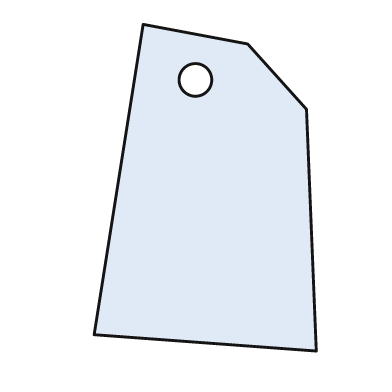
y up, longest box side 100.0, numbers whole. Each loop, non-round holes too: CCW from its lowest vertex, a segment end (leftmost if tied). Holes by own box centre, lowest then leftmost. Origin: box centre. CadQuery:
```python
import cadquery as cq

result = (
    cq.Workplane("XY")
    .moveTo(34.0, -50.0)
    .lineTo(31.0, 24.0)
    .lineTo(13.0, 44.0)
    .lineTo(-19.0, 50.0)
    .lineTo(-34.0, -45.0)
    .close()
    .moveTo(-3.0, 33.0)
    .circle(5.0)
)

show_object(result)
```